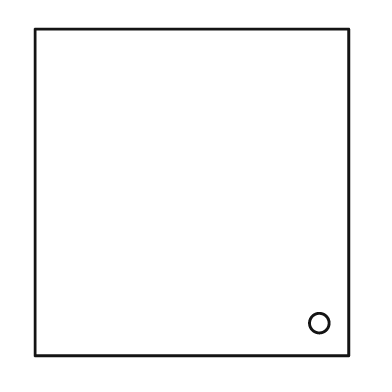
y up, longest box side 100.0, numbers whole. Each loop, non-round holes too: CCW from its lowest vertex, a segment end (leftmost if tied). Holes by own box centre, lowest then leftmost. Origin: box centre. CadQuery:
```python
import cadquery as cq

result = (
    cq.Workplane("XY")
    .moveTo(-48.0, -50.0)
    .lineTo(48.0, -50.0)
    .lineTo(48.0, 50.0)
    .lineTo(-48.0, 50.0)
    .close()
    .moveTo(39.0, -40.0)
    .circle(3.0)
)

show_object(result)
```